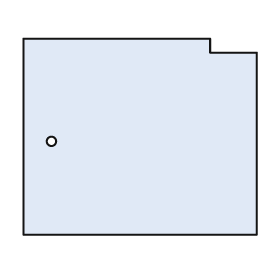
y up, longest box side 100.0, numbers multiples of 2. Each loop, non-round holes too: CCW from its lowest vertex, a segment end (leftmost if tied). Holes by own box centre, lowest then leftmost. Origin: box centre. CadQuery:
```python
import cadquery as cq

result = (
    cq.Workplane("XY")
    .moveTo(-50.0, -42.0)
    .lineTo(50.0, -42.0)
    .lineTo(50.0, 36.0)
    .lineTo(30.0, 36.0)
    .lineTo(30.0, 42.0)
    .lineTo(-50.0, 42.0)
    .close()
    .moveTo(-38.0, -2.0)
    .circle(2.0)
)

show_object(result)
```